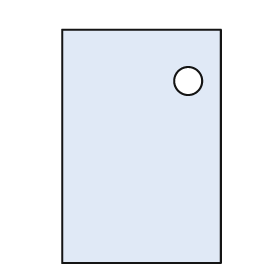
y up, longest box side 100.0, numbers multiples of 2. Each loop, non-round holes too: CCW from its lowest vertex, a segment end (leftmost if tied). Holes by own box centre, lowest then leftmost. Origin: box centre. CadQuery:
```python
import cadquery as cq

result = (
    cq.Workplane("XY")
    .moveTo(-34.0, -50.0)
    .lineTo(34.0, -50.0)
    .lineTo(34.0, 50.0)
    .lineTo(-34.0, 50.0)
    .close()
    .moveTo(20.0, 28.0)
    .circle(6.0)
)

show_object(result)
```